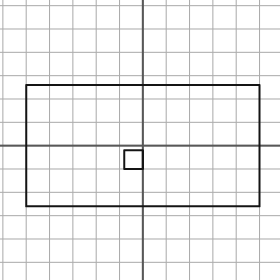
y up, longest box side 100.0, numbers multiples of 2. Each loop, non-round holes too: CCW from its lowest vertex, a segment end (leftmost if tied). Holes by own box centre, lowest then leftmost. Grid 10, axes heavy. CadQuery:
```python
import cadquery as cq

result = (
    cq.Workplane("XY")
    .moveTo(-50.0, -26.0)
    .lineTo(50.0, -26.0)
    .lineTo(50.0, 26.0)
    .lineTo(-50.0, 26.0)
    .close()
    .moveTo(-8.0, -10.0)
    .lineTo(0.0, -10.0)
    .lineTo(0.0, -2.0)
    .lineTo(-8.0, -2.0)
    .close()
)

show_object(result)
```